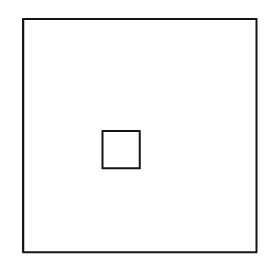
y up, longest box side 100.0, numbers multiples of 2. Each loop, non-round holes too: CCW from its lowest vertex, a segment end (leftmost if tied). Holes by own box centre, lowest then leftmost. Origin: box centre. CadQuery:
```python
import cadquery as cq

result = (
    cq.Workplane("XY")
    .moveTo(-50.0, -50.0)
    .lineTo(50.0, -50.0)
    .lineTo(50.0, 50.0)
    .lineTo(-50.0, 50.0)
    .close()
    .moveTo(-16.0, -14.0)
    .lineTo(0.0, -14.0)
    .lineTo(0.0, 2.0)
    .lineTo(-16.0, 2.0)
    .close()
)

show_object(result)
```